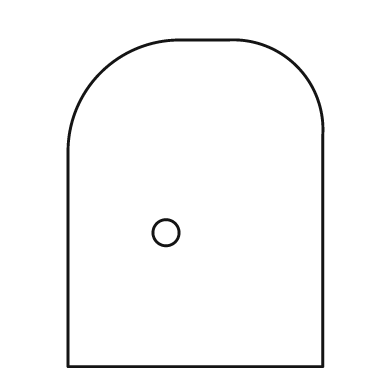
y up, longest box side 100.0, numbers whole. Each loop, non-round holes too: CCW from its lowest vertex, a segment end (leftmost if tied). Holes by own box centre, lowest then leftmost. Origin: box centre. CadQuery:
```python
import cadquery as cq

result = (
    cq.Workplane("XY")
    .moveTo(-39.0, -50.0)
    .lineTo(39.0, -50.0)
    .lineTo(39.0, 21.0)
    .threePointArc((31.0, 42.0), (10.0, 50.0))
    .lineTo(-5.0, 50.0)
    .threePointArc((-29.0, 40.0), (-39.0, 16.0))
    .close()
    .moveTo(-9.0, -9.0)
    .circle(4.0)
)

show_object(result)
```